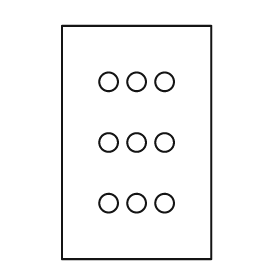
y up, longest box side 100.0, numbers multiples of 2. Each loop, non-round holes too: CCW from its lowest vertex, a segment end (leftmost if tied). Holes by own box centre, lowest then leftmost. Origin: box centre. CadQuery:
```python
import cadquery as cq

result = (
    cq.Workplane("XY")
    .moveTo(-32.0, -50.0)
    .lineTo(32.0, -50.0)
    .lineTo(32.0, 50.0)
    .lineTo(-32.0, 50.0)
    .close()
    .moveTo(-12.0, -26.0)
    .circle(4.0)
    .moveTo(0.0, -26.0)
    .circle(4.0)
    .moveTo(12.0, -26.0)
    .circle(4.0)
    .moveTo(-12.0, 0.0)
    .circle(4.0)
    .moveTo(0.0, 0.0)
    .circle(4.0)
    .moveTo(12.0, 0.0)
    .circle(4.0)
    .moveTo(-12.0, 26.0)
    .circle(4.0)
    .moveTo(0.0, 26.0)
    .circle(4.0)
    .moveTo(12.0, 26.0)
    .circle(4.0)
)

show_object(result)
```